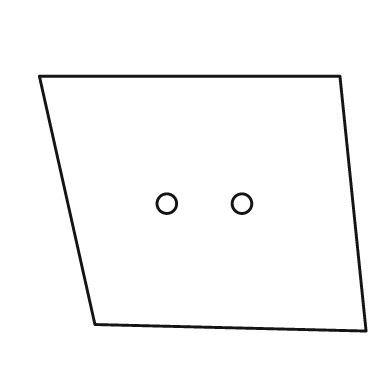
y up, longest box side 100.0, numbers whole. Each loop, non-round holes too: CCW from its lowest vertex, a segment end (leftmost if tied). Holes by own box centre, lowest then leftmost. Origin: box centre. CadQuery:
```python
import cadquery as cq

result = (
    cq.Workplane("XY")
    .moveTo(50.0, -39.0)
    .lineTo(42.0, 39.0)
    .lineTo(-50.0, 39.0)
    .lineTo(-33.0, -37.0)
    .close()
    .moveTo(-11.0, 0.0)
    .circle(3.0)
    .moveTo(12.0, 0.0)
    .circle(3.0)
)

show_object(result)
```